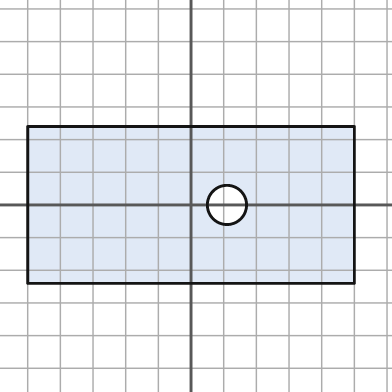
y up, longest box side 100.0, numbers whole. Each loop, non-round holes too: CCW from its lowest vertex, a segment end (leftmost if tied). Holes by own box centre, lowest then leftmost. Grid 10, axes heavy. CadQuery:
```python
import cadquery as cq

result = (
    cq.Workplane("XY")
    .moveTo(-50.0, -24.0)
    .lineTo(50.0, -24.0)
    .lineTo(50.0, 24.0)
    .lineTo(-50.0, 24.0)
    .close()
    .moveTo(11.0, 0.0)
    .circle(6.0)
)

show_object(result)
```